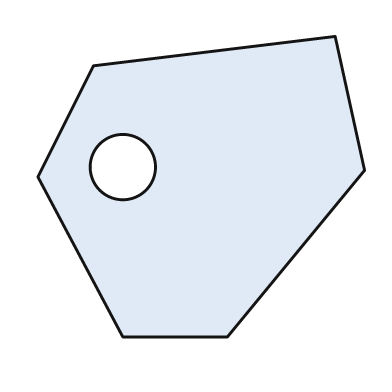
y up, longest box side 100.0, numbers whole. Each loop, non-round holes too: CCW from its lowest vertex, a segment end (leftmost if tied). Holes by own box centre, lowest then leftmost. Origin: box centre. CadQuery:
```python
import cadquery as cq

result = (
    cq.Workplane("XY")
    .moveTo(-24.0, -46.0)
    .lineTo(8.0, -46.0)
    .lineTo(50.0, 5.0)
    .lineTo(41.0, 46.0)
    .lineTo(-33.0, 37.0)
    .lineTo(-50.0, 3.0)
    .close()
    .moveTo(-24.0, 6.0)
    .circle(10.0)
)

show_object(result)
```